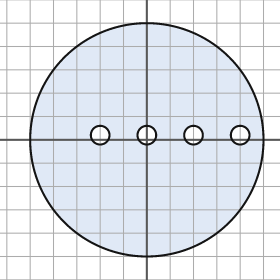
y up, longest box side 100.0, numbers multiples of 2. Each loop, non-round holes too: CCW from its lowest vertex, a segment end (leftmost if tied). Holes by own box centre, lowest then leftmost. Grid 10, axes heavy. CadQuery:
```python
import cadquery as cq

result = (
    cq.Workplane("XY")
    .moveTo(0.0, 0.0)
    .circle(50.0)
    .moveTo(-20.0, 2.0)
    .circle(4.0)
    .moveTo(0.0, 2.0)
    .circle(4.0)
    .moveTo(20.0, 2.0)
    .circle(4.0)
    .moveTo(40.0, 2.0)
    .circle(4.0)
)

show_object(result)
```